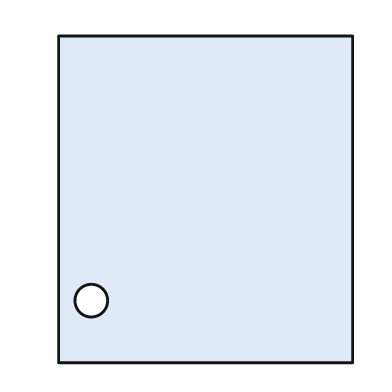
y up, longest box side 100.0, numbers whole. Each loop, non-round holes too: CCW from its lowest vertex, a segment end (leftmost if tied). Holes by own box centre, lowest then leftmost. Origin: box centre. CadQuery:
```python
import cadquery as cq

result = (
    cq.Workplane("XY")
    .moveTo(-45.0, -50.0)
    .lineTo(45.0, -50.0)
    .lineTo(45.0, 50.0)
    .lineTo(-45.0, 50.0)
    .close()
    .moveTo(-35.0, -31.0)
    .circle(5.0)
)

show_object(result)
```